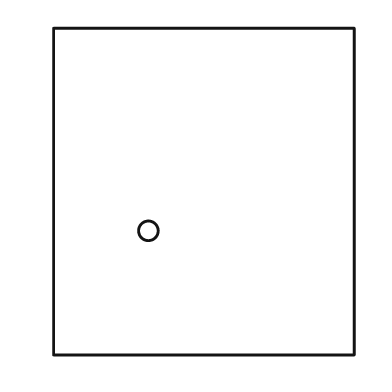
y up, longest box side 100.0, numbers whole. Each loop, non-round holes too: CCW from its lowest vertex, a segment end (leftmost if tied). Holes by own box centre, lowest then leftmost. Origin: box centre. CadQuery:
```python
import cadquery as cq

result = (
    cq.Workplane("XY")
    .moveTo(-46.0, -50.0)
    .lineTo(46.0, -50.0)
    .lineTo(46.0, 50.0)
    .lineTo(-46.0, 50.0)
    .close()
    .moveTo(-17.0, -12.0)
    .circle(3.0)
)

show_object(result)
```